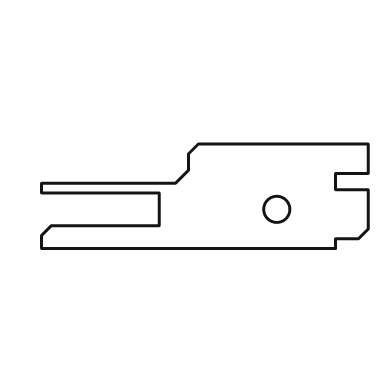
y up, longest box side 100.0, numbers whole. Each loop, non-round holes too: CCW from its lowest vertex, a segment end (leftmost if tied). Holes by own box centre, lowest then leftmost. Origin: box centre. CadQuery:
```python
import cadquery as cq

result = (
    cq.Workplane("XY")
    .moveTo(-50.0, -16.0)
    .lineTo(40.0, -16.0)
    .lineTo(40.0, -13.0)
    .lineTo(47.0, -13.0)
    .lineTo(50.0, -10.0)
    .lineTo(50.0, 2.0)
    .lineTo(40.0, 2.0)
    .lineTo(40.0, 7.0)
    .lineTo(50.0, 7.0)
    .lineTo(50.0, 16.0)
    .lineTo(-2.0, 16.0)
    .lineTo(-5.0, 13.0)
    .lineTo(-5.0, 8.0)
    .lineTo(-9.0, 4.0)
    .lineTo(-50.0, 4.0)
    .lineTo(-50.0, 1.0)
    .lineTo(-14.0, 1.0)
    .lineTo(-14.0, -9.0)
    .lineTo(-47.0, -9.0)
    .lineTo(-50.0, -12.0)
    .close()
    .moveTo(22.0, -4.0)
    .circle(4.0)
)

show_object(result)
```